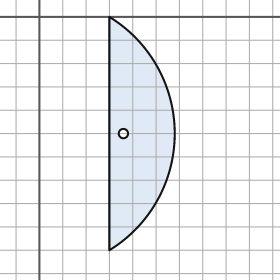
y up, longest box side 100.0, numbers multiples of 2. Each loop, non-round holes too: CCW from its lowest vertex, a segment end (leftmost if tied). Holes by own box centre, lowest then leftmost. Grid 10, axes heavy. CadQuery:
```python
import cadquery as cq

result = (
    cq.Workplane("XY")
    .moveTo(30.0, -100.0)
    .threePointArc((58.0, -50.0), (30.0, 0.0))
    .close()
    .moveTo(36.0, -50.0)
    .circle(2.0)
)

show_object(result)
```